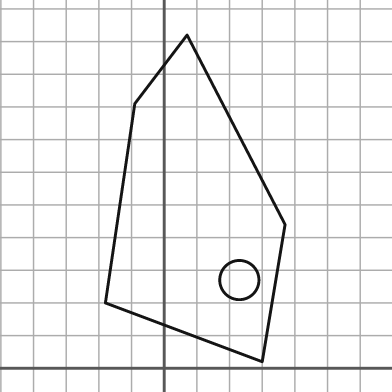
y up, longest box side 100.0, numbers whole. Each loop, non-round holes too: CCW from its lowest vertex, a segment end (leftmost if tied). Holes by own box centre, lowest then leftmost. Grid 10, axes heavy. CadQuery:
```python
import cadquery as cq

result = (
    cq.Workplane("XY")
    .moveTo(30.0, 2.0)
    .lineTo(37.0, 44.0)
    .lineTo(7.0, 102.0)
    .lineTo(-9.0, 81.0)
    .lineTo(-18.0, 20.0)
    .close()
    .moveTo(23.0, 27.0)
    .circle(6.0)
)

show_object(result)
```